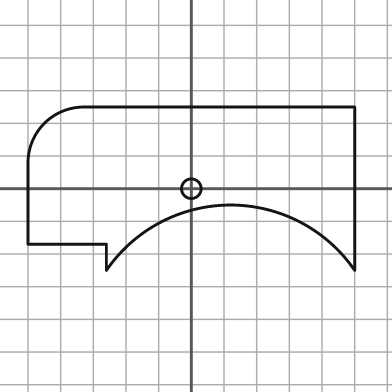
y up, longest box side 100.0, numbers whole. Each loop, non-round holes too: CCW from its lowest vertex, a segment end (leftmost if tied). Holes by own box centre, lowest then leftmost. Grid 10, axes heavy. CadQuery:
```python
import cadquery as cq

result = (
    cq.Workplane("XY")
    .moveTo(-26.0, -25.0)
    .threePointArc((12.0, -5.0), (50.0, -25.0))
    .lineTo(50.0, 25.0)
    .lineTo(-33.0, 25.0)
    .threePointArc((-45.0, 20.0), (-50.0, 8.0))
    .lineTo(-50.0, -17.0)
    .lineTo(-26.0, -17.0)
    .close()
    .moveTo(0.0, 0.0)
    .circle(3.0)
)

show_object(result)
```